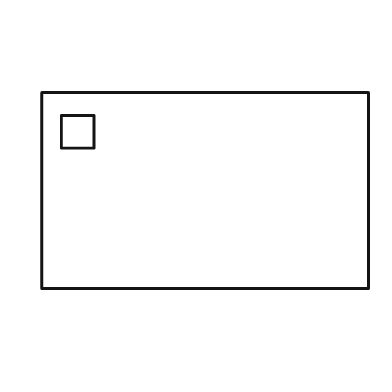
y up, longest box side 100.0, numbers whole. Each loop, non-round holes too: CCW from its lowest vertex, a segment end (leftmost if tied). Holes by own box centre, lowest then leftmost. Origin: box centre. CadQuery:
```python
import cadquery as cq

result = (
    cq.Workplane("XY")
    .moveTo(-50.0, -30.0)
    .lineTo(50.0, -30.0)
    .lineTo(50.0, 30.0)
    .lineTo(-50.0, 30.0)
    .close()
    .moveTo(-44.0, 13.0)
    .lineTo(-34.0, 13.0)
    .lineTo(-34.0, 23.0)
    .lineTo(-44.0, 23.0)
    .close()
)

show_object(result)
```